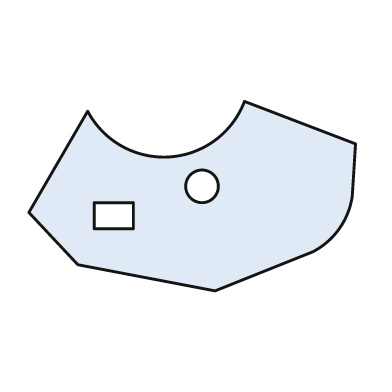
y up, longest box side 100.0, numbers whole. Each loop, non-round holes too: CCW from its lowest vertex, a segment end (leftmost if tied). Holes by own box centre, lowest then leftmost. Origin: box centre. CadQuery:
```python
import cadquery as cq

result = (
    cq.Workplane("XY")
    .moveTo(7.0, -29.0)
    .lineTo(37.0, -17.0)
    .threePointArc((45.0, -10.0), (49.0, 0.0))
    .lineTo(50.0, 16.0)
    .lineTo(16.0, 29.0)
    .threePointArc((-7.0, 12.0), (-32.0, 26.0))
    .lineTo(-50.0, -5.0)
    .lineTo(-35.0, -21.0)
    .close()
    .moveTo(-30.0, -10.0)
    .lineTo(-18.0, -10.0)
    .lineTo(-18.0, -2.0)
    .lineTo(-30.0, -2.0)
    .close()
    .moveTo(3.0, 3.0)
    .circle(5.0)
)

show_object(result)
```